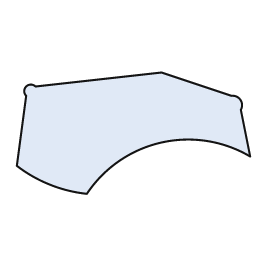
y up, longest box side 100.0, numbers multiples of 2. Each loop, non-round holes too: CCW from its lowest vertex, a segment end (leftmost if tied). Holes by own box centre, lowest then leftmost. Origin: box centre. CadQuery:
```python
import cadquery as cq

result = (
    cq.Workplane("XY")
    .moveTo(-20.0, -26.0)
    .threePointArc((12.0, -4.0), (50.0, -10.0))
    .lineTo(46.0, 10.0)
    .threePointArc((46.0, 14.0), (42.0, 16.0))
    .lineTo(12.0, 26.0)
    .lineTo(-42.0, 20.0)
    .threePointArc((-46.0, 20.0), (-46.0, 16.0))
    .lineTo(-50.0, -14.0)
    .threePointArc((-36.0, -22.0), (-20.0, -26.0))
    .close()
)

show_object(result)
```